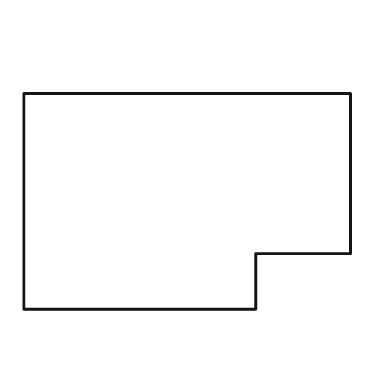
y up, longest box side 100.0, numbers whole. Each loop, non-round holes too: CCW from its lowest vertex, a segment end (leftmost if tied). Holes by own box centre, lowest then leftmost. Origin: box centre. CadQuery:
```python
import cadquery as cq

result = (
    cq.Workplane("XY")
    .moveTo(-50.0, -33.0)
    .lineTo(21.0, -33.0)
    .lineTo(21.0, -16.0)
    .lineTo(50.0, -16.0)
    .lineTo(50.0, 33.0)
    .lineTo(-50.0, 33.0)
    .close()
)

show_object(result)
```